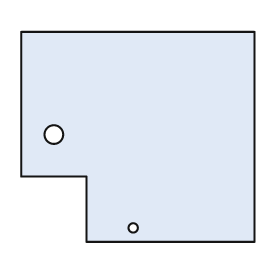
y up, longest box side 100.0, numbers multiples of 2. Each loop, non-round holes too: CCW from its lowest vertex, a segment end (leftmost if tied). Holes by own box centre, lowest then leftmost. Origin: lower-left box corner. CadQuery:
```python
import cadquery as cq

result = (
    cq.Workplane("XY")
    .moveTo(28.0, 0.0)
    .lineTo(100.0, 0.0)
    .lineTo(100.0, 90.0)
    .lineTo(0.0, 90.0)
    .lineTo(0.0, 28.0)
    .lineTo(28.0, 28.0)
    .close()
    .moveTo(48.0, 6.0)
    .circle(2.0)
    .moveTo(14.0, 46.0)
    .circle(4.0)
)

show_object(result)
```